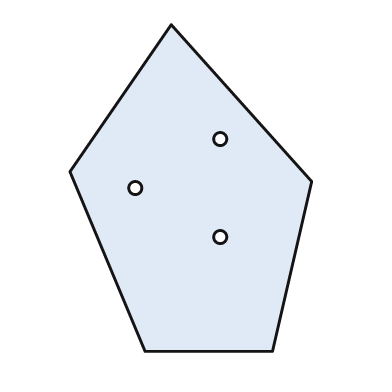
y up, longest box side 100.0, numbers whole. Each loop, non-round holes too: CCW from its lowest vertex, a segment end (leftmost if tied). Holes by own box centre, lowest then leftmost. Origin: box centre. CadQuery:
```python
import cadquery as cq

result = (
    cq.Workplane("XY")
    .moveTo(-14.0, -50.0)
    .lineTo(25.0, -50.0)
    .lineTo(37.0, 2.0)
    .lineTo(-6.0, 50.0)
    .lineTo(-37.0, 5.0)
    .close()
    .moveTo(9.0, -15.0)
    .circle(2.0)
    .moveTo(-17.0, 0.0)
    .circle(2.0)
    .moveTo(9.0, 15.0)
    .circle(2.0)
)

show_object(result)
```